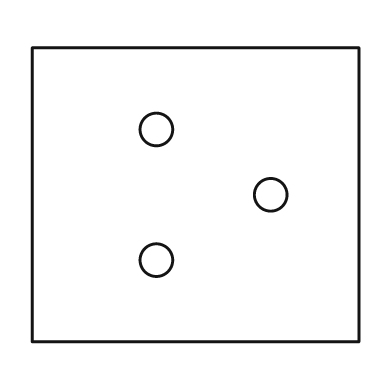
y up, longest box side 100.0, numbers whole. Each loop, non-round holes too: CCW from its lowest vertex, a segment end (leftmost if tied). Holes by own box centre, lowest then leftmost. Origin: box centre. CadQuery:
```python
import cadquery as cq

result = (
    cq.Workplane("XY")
    .moveTo(-50.0, -45.0)
    .lineTo(50.0, -45.0)
    .lineTo(50.0, 45.0)
    .lineTo(-50.0, 45.0)
    .close()
    .moveTo(-12.0, -20.0)
    .circle(5.0)
    .moveTo(23.0, 0.0)
    .circle(5.0)
    .moveTo(-12.0, 20.0)
    .circle(5.0)
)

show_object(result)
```